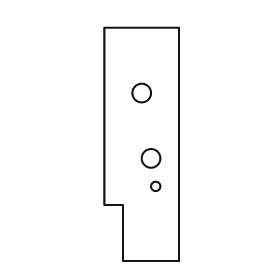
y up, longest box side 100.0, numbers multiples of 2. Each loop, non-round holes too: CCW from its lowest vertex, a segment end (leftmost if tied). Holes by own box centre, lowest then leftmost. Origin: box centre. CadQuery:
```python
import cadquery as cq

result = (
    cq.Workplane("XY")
    .moveTo(-8.0, -50.0)
    .lineTo(16.0, -50.0)
    .lineTo(16.0, 50.0)
    .lineTo(-16.0, 50.0)
    .lineTo(-16.0, -26.0)
    .lineTo(-8.0, -26.0)
    .close()
    .moveTo(6.0, -18.0)
    .circle(2.0)
    .moveTo(4.0, -6.0)
    .circle(4.0)
    .moveTo(0.0, 22.0)
    .circle(4.0)
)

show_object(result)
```